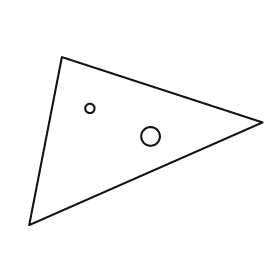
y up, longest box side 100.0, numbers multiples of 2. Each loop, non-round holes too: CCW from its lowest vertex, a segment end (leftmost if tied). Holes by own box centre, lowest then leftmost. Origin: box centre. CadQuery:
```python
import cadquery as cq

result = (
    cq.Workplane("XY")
    .moveTo(-50.0, -36.0)
    .lineTo(50.0, 8.0)
    .lineTo(-36.0, 36.0)
    .close()
    .moveTo(2.0, 2.0)
    .circle(4.0)
    .moveTo(-24.0, 14.0)
    .circle(2.0)
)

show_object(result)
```